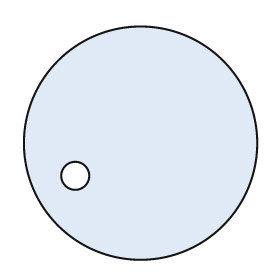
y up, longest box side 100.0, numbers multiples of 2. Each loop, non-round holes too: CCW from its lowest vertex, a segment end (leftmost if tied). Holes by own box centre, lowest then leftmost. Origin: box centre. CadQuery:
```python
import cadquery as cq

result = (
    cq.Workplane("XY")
    .moveTo(0.0, 0.0)
    .circle(50.0)
    .moveTo(-28.0, -14.0)
    .circle(6.0)
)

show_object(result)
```